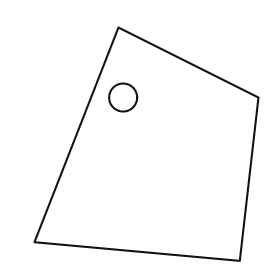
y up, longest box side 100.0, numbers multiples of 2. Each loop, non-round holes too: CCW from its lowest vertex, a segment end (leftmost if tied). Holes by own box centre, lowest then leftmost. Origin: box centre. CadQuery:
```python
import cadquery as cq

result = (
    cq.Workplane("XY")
    .moveTo(40.0, -50.0)
    .lineTo(48.0, 20.0)
    .lineTo(-12.0, 50.0)
    .lineTo(-48.0, -42.0)
    .close()
    .moveTo(-10.0, 20.0)
    .circle(6.0)
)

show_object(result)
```